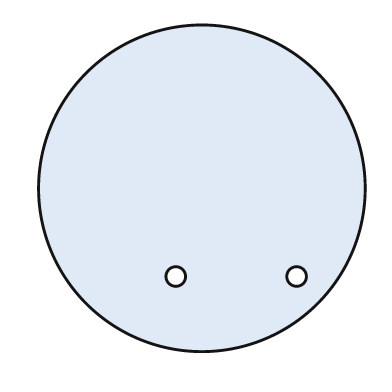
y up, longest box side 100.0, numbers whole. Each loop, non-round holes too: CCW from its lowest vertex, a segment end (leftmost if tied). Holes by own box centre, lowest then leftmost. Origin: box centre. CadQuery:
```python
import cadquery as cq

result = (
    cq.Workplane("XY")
    .moveTo(0.0, 0.0)
    .circle(50.0)
    .moveTo(-8.0, -27.0)
    .circle(3.0)
    .moveTo(29.0, -27.0)
    .circle(3.0)
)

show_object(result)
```